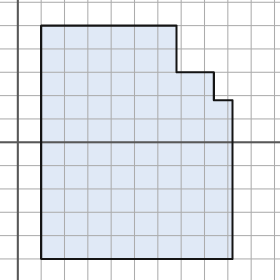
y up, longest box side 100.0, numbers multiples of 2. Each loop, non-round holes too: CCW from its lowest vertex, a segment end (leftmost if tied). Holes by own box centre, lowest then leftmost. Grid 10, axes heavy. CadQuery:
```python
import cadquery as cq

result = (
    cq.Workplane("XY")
    .moveTo(10.0, -50.0)
    .lineTo(92.0, -50.0)
    .lineTo(92.0, 18.0)
    .lineTo(84.0, 18.0)
    .lineTo(84.0, 30.0)
    .lineTo(68.0, 30.0)
    .lineTo(68.0, 50.0)
    .lineTo(10.0, 50.0)
    .close()
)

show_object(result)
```